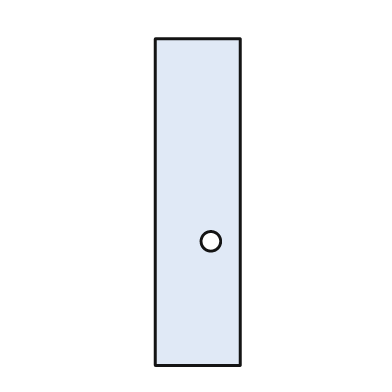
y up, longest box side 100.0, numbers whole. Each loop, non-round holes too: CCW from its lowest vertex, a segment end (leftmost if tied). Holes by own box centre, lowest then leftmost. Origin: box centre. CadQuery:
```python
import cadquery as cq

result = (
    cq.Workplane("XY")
    .moveTo(-13.0, -50.0)
    .lineTo(13.0, -50.0)
    .lineTo(13.0, 50.0)
    .lineTo(-13.0, 50.0)
    .close()
    .moveTo(4.0, -12.0)
    .circle(3.0)
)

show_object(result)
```